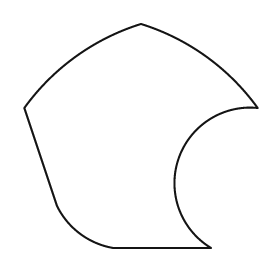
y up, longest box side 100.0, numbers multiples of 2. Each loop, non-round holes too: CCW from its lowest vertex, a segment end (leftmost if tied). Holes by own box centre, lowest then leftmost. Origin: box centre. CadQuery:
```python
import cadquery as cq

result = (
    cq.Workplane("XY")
    .moveTo(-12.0, -48.0)
    .lineTo(30.0, -48.0)
    .threePointArc((16.0, -10.0), (50.0, 12.0))
    .threePointArc((28.0, 34.0), (0.0, 48.0))
    .threePointArc((-28.0, 34.0), (-50.0, 12.0))
    .lineTo(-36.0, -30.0)
    .threePointArc((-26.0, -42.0), (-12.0, -48.0))
    .close()
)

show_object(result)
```